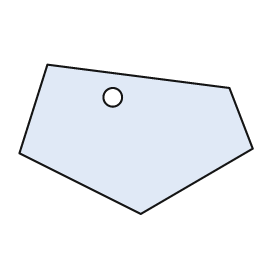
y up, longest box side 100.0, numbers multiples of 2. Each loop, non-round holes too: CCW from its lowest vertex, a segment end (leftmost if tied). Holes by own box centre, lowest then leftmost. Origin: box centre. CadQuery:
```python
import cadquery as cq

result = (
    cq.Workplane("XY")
    .moveTo(2.0, -32.0)
    .lineTo(50.0, -4.0)
    .lineTo(40.0, 22.0)
    .lineTo(-38.0, 32.0)
    .lineTo(-50.0, -6.0)
    .close()
    .moveTo(-10.0, 18.0)
    .circle(4.0)
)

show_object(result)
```